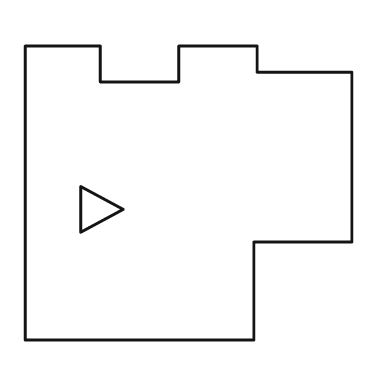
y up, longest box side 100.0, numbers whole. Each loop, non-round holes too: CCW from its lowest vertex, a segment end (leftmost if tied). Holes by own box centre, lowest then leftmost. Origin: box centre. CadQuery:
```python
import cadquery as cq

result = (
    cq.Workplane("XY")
    .moveTo(-50.0, -45.0)
    .lineTo(20.0, -45.0)
    .lineTo(20.0, -15.0)
    .lineTo(50.0, -15.0)
    .lineTo(50.0, 37.0)
    .lineTo(21.0, 37.0)
    .lineTo(21.0, 45.0)
    .lineTo(-3.0, 45.0)
    .lineTo(-3.0, 34.0)
    .lineTo(-27.0, 34.0)
    .lineTo(-27.0, 45.0)
    .lineTo(-50.0, 45.0)
    .close()
    .moveTo(-33.0, -12.0)
    .lineTo(-20.0, -5.0)
    .lineTo(-33.0, 2.0)
    .close()
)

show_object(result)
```